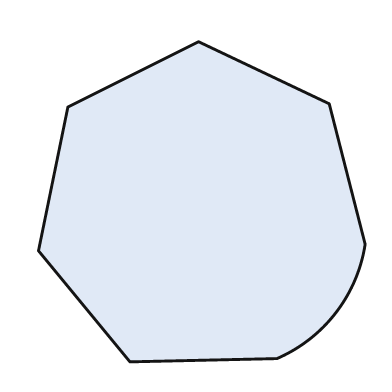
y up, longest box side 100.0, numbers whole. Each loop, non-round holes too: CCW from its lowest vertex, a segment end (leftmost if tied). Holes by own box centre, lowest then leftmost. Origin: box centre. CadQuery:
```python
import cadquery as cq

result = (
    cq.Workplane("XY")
    .moveTo(-22.0, -49.0)
    .lineTo(23.0, -48.0)
    .threePointArc((41.0, -34.0), (50.0, -13.0))
    .lineTo(39.0, 30.0)
    .lineTo(-1.0, 49.0)
    .lineTo(-41.0, 29.0)
    .lineTo(-50.0, -15.0)
    .close()
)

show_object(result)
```